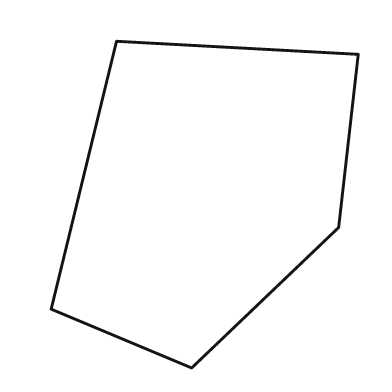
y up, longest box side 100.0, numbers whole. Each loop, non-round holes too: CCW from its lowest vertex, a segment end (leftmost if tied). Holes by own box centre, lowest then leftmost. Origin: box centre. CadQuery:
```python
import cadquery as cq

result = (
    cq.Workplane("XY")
    .moveTo(-4.0, -50.0)
    .lineTo(41.0, -7.0)
    .lineTo(47.0, 46.0)
    .lineTo(-27.0, 50.0)
    .lineTo(-47.0, -32.0)
    .close()
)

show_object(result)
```